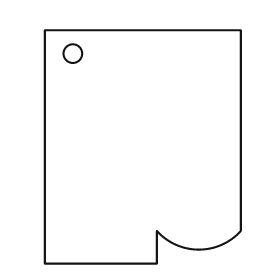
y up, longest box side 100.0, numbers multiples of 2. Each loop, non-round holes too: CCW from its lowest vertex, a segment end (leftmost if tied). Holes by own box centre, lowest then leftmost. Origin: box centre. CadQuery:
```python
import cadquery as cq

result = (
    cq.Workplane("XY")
    .moveTo(-42.0, -50.0)
    .lineTo(6.0, -50.0)
    .lineTo(6.0, -36.0)
    .threePointArc((24.0, -44.0), (42.0, -36.0))
    .lineTo(42.0, 50.0)
    .lineTo(-42.0, 50.0)
    .close()
    .moveTo(-30.0, 40.0)
    .circle(4.0)
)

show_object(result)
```